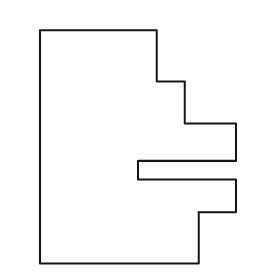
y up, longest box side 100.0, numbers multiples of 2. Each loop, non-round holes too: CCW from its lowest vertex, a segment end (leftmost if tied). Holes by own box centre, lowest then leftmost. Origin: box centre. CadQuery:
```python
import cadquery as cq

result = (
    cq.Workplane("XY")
    .moveTo(-42.0, -50.0)
    .lineTo(26.0, -50.0)
    .lineTo(26.0, -28.0)
    .lineTo(42.0, -28.0)
    .lineTo(42.0, -14.0)
    .lineTo(0.0, -14.0)
    .lineTo(0.0, -6.0)
    .lineTo(42.0, -6.0)
    .lineTo(42.0, 10.0)
    .lineTo(20.0, 10.0)
    .lineTo(20.0, 28.0)
    .lineTo(8.0, 28.0)
    .lineTo(8.0, 50.0)
    .lineTo(-42.0, 50.0)
    .close()
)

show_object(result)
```